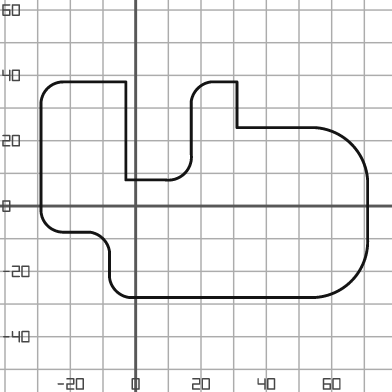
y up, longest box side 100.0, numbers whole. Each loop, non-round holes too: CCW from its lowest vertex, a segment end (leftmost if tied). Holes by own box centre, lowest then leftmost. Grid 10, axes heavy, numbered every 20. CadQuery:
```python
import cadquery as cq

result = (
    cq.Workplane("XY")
    .moveTo(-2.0, -28.0)
    .lineTo(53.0, -28.0)
    .threePointArc((66.0, -23.0), (71.0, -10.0))
    .lineTo(71.0, 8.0)
    .threePointArc((66.0, 19.0), (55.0, 24.0))
    .lineTo(31.0, 24.0)
    .lineTo(31.0, 38.0)
    .lineTo(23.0, 38.0)
    .threePointArc((19.0, 36.0), (17.0, 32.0))
    .lineTo(17.0, 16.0)
    .threePointArc((15.0, 10.0), (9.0, 8.0))
    .lineTo(-3.0, 8.0)
    .lineTo(-3.0, 38.0)
    .lineTo(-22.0, 38.0)
    .threePointArc((-27.0, 36.0), (-29.0, 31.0))
    .lineTo(-29.0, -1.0)
    .threePointArc((-27.0, -6.0), (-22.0, -8.0))
    .lineTo(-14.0, -8.0)
    .threePointArc((-10.0, -10.0), (-8.0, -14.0))
    .lineTo(-8.0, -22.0)
    .threePointArc((-6.0, -26.0), (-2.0, -28.0))
    .close()
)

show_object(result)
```